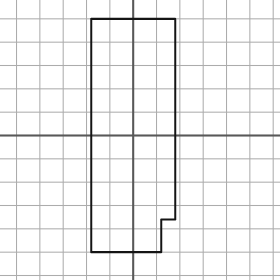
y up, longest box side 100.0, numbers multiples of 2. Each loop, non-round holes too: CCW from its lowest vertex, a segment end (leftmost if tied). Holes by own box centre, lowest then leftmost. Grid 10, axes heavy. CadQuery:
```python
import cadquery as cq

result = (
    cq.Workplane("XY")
    .moveTo(-18.0, -50.0)
    .lineTo(12.0, -50.0)
    .lineTo(12.0, -36.0)
    .lineTo(18.0, -36.0)
    .lineTo(18.0, 50.0)
    .lineTo(-18.0, 50.0)
    .close()
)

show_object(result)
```